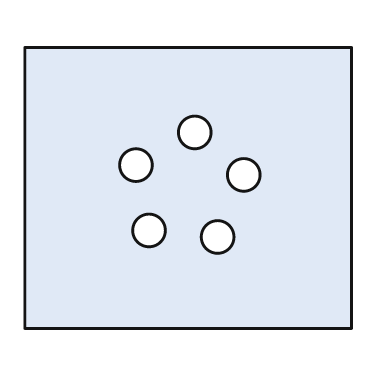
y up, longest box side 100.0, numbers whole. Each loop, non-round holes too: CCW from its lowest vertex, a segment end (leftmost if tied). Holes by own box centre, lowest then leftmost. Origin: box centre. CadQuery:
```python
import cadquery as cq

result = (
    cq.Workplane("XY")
    .moveTo(-50.0, -43.0)
    .lineTo(50.0, -43.0)
    .lineTo(50.0, 43.0)
    .lineTo(-50.0, 43.0)
    .close()
    .moveTo(9.0, -15.0)
    .circle(5.0)
    .moveTo(-12.0, -13.0)
    .circle(5.0)
    .moveTo(17.0, 4.0)
    .circle(5.0)
    .moveTo(-16.0, 7.0)
    .circle(5.0)
    .moveTo(2.0, 17.0)
    .circle(5.0)
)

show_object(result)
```